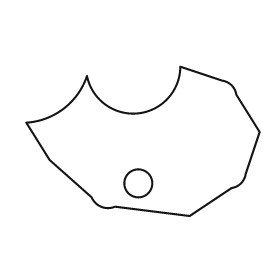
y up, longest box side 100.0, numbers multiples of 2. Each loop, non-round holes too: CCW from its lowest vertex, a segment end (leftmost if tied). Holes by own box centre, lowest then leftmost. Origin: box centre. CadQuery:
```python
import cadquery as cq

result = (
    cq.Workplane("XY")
    .moveTo(20.0, -32.0)
    .lineTo(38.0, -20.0)
    .threePointArc((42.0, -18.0), (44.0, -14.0))
    .lineTo(50.0, 4.0)
    .lineTo(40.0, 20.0)
    .threePointArc((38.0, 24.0), (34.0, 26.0))
    .lineTo(16.0, 32.0)
    .threePointArc((-2.0, 12.0), (-24.0, 28.0))
    .threePointArc((-34.0, 14.0), (-50.0, 8.0))
    .lineTo(-40.0, -8.0)
    .lineTo(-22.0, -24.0)
    .threePointArc((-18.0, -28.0), (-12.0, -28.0))
    .close()
    .moveTo(-2.0, -18.0)
    .circle(6.0)
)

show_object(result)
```